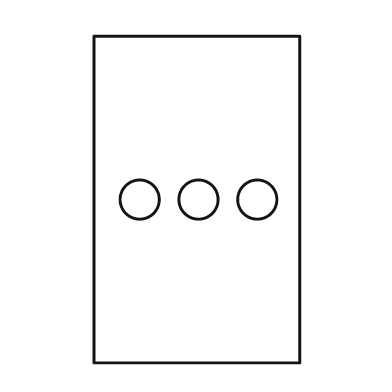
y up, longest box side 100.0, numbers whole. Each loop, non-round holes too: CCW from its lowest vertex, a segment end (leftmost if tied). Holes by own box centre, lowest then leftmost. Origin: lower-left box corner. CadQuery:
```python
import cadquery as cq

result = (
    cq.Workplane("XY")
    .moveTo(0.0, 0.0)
    .lineTo(63.0, 0.0)
    .lineTo(63.0, 100.0)
    .lineTo(0.0, 100.0)
    .close()
    .moveTo(14.0, 50.0)
    .circle(6.0)
    .moveTo(32.0, 50.0)
    .circle(6.0)
    .moveTo(50.0, 50.0)
    .circle(6.0)
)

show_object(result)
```